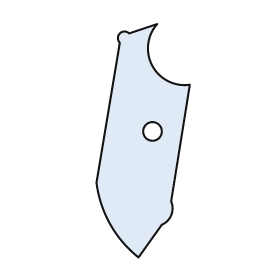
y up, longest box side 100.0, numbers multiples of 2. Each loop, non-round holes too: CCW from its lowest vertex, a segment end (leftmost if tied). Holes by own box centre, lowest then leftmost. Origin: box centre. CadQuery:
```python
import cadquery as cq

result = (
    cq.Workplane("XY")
    .moveTo(-2.0, -50.0)
    .lineTo(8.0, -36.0)
    .threePointArc((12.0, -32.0), (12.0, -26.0))
    .lineTo(20.0, 24.0)
    .threePointArc((4.0, 32.0), (6.0, 50.0))
    .lineTo(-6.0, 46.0)
    .threePointArc((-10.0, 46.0), (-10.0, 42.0))
    .lineTo(-20.0, -18.0)
    .threePointArc((-14.0, -36.0), (-2.0, -50.0))
    .close()
    .moveTo(4.0, 4.0)
    .circle(4.0)
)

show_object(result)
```